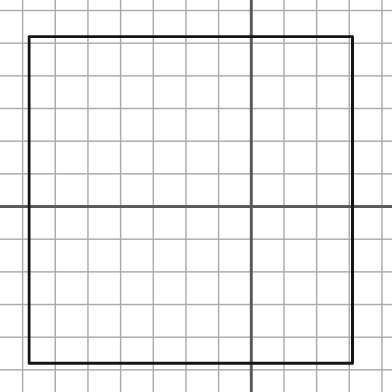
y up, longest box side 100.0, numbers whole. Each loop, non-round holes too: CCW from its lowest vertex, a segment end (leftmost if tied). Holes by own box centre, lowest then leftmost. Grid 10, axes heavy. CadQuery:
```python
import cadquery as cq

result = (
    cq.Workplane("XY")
    .moveTo(-68.0, -48.0)
    .lineTo(31.0, -48.0)
    .lineTo(31.0, 52.0)
    .lineTo(-68.0, 52.0)
    .close()
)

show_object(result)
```